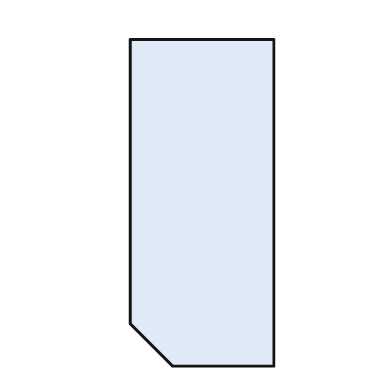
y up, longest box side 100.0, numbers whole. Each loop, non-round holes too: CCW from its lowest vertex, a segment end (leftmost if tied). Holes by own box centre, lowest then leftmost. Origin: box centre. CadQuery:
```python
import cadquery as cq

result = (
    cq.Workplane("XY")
    .moveTo(-9.0, -50.0)
    .lineTo(22.0, -50.0)
    .lineTo(22.0, 50.0)
    .lineTo(-22.0, 50.0)
    .lineTo(-22.0, -37.0)
    .close()
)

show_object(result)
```